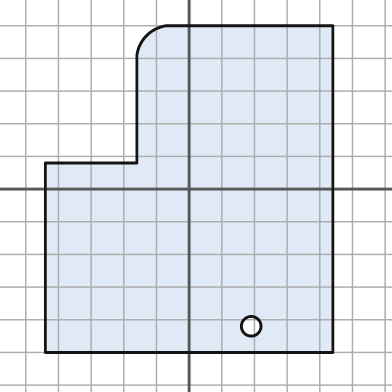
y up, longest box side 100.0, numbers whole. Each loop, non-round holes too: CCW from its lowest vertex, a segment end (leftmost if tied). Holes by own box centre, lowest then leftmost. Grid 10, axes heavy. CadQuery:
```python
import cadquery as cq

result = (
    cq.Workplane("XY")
    .moveTo(-44.0, -50.0)
    .lineTo(44.0, -50.0)
    .lineTo(44.0, 50.0)
    .lineTo(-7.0, 50.0)
    .threePointArc((-13.0, 47.0), (-16.0, 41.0))
    .lineTo(-16.0, 8.0)
    .lineTo(-44.0, 8.0)
    .close()
    .moveTo(19.0, -42.0)
    .circle(3.0)
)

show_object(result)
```